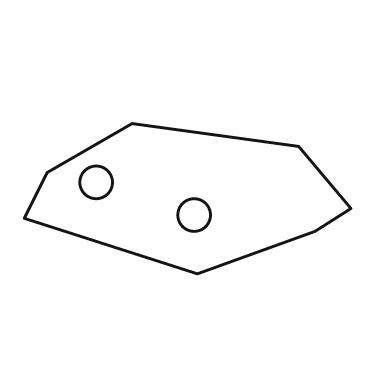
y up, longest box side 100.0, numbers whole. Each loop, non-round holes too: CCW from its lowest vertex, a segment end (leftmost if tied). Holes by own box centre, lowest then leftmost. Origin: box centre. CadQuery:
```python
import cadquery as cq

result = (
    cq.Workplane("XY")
    .moveTo(3.0, -23.0)
    .lineTo(39.0, -10.0)
    .lineTo(50.0, -3.0)
    .lineTo(34.0, 16.0)
    .lineTo(-17.0, 23.0)
    .lineTo(-43.0, 8.0)
    .lineTo(-50.0, -6.0)
    .close()
    .moveTo(2.0, -5.0)
    .circle(5.0)
    .moveTo(-28.0, 5.0)
    .circle(5.0)
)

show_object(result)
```